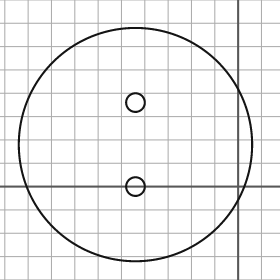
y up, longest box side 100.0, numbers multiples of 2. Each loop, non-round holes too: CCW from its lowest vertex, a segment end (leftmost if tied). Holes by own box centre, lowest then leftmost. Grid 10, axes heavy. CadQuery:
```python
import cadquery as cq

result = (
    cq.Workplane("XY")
    .moveTo(-44.0, 18.0)
    .circle(50.0)
    .moveTo(-44.0, 0.0)
    .circle(4.0)
    .moveTo(-44.0, 36.0)
    .circle(4.0)
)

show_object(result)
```